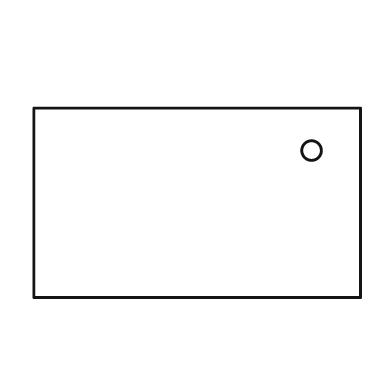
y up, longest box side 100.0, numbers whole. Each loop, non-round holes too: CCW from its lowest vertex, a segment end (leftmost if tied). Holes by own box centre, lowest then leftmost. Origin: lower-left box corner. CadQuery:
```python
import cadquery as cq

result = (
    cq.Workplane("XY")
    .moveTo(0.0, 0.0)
    .lineTo(100.0, 0.0)
    .lineTo(100.0, 58.0)
    .lineTo(0.0, 58.0)
    .close()
    .moveTo(85.0, 45.0)
    .circle(3.0)
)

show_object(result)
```